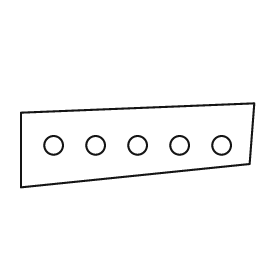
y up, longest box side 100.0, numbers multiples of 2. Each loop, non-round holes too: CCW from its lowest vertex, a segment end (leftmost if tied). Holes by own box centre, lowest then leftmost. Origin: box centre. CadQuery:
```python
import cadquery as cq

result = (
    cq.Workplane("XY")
    .moveTo(-50.0, -18.0)
    .lineTo(48.0, -8.0)
    .lineTo(50.0, 18.0)
    .lineTo(-50.0, 14.0)
    .close()
    .moveTo(-36.0, 0.0)
    .circle(4.0)
    .moveTo(-18.0, 0.0)
    .circle(4.0)
    .moveTo(0.0, 0.0)
    .circle(4.0)
    .moveTo(18.0, 0.0)
    .circle(4.0)
    .moveTo(36.0, 0.0)
    .circle(4.0)
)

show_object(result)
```